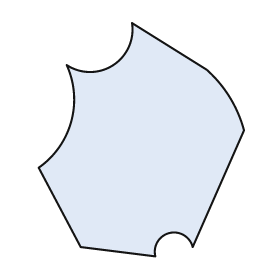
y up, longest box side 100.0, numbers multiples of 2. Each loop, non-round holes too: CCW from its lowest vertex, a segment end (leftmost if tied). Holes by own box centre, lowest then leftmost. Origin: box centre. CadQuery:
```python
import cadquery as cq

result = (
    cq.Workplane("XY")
    .moveTo(6.0, -50.0)
    .threePointArc((12.0, -40.0), (22.0, -46.0))
    .lineTo(44.0, 4.0)
    .threePointArc((38.0, 18.0), (28.0, 30.0))
    .lineTo(-4.0, 50.0)
    .threePointArc((-12.0, 32.0), (-32.0, 32.0))
    .threePointArc((-30.0, 8.0), (-44.0, -12.0))
    .lineTo(-26.0, -46.0)
    .close()
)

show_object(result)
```